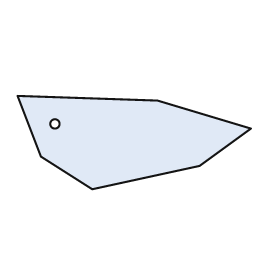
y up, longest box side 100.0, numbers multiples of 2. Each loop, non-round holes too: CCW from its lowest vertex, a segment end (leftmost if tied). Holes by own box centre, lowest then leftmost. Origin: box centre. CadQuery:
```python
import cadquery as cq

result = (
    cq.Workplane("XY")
    .moveTo(-18.0, -20.0)
    .lineTo(28.0, -10.0)
    .lineTo(50.0, 6.0)
    .lineTo(10.0, 18.0)
    .lineTo(-50.0, 20.0)
    .lineTo(-40.0, -6.0)
    .close()
    .moveTo(-34.0, 8.0)
    .circle(2.0)
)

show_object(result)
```